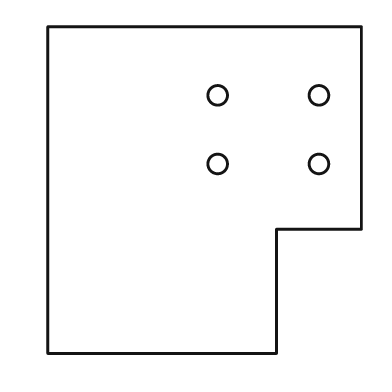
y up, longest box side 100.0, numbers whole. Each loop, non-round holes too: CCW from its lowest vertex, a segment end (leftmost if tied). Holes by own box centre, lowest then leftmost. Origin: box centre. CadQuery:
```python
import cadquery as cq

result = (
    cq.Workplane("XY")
    .moveTo(-48.0, -50.0)
    .lineTo(22.0, -50.0)
    .lineTo(22.0, -12.0)
    .lineTo(48.0, -12.0)
    .lineTo(48.0, 50.0)
    .lineTo(-48.0, 50.0)
    .close()
    .moveTo(4.0, 8.0)
    .circle(3.0)
    .moveTo(35.0, 8.0)
    .circle(3.0)
    .moveTo(4.0, 29.0)
    .circle(3.0)
    .moveTo(35.0, 29.0)
    .circle(3.0)
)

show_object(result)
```